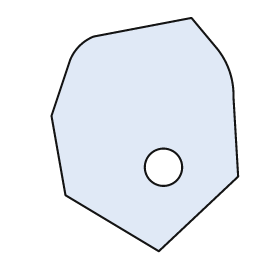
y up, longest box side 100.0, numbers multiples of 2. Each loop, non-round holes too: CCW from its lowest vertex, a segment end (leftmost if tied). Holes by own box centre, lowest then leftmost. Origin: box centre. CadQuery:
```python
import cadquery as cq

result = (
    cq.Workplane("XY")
    .moveTo(6.0, -50.0)
    .lineTo(40.0, -18.0)
    .lineTo(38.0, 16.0)
    .threePointArc((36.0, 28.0), (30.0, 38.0))
    .lineTo(20.0, 50.0)
    .lineTo(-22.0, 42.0)
    .threePointArc((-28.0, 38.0), (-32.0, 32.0))
    .lineTo(-40.0, 8.0)
    .lineTo(-34.0, -26.0)
    .close()
    .moveTo(8.0, -14.0)
    .circle(8.0)
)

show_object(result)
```